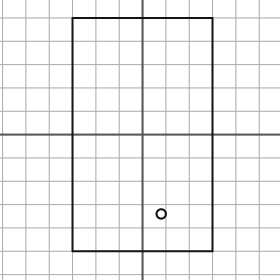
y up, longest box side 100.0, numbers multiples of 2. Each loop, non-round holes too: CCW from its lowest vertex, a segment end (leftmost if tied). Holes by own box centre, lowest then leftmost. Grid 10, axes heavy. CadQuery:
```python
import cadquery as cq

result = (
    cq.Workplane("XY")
    .moveTo(-30.0, -50.0)
    .lineTo(30.0, -50.0)
    .lineTo(30.0, 50.0)
    .lineTo(-30.0, 50.0)
    .close()
    .moveTo(8.0, -34.0)
    .circle(2.0)
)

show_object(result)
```